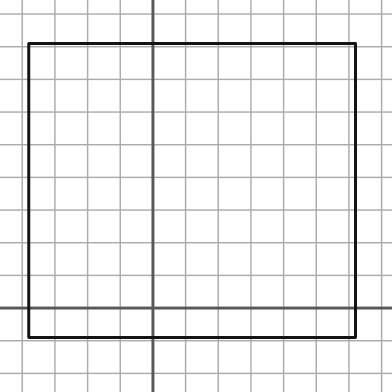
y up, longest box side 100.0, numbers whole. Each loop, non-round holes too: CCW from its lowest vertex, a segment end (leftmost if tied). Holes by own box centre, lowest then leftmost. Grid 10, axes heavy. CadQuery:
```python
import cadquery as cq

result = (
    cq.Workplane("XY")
    .moveTo(-38.0, -9.0)
    .lineTo(62.0, -9.0)
    .lineTo(62.0, 81.0)
    .lineTo(-38.0, 81.0)
    .close()
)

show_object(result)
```